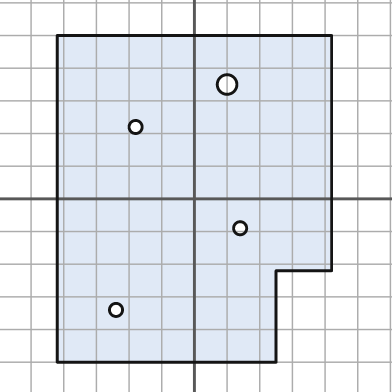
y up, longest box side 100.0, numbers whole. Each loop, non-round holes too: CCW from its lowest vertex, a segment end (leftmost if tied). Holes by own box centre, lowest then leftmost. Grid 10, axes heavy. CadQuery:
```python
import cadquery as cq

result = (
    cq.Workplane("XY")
    .moveTo(-42.0, -50.0)
    .lineTo(25.0, -50.0)
    .lineTo(25.0, -22.0)
    .lineTo(42.0, -22.0)
    .lineTo(42.0, 50.0)
    .lineTo(-42.0, 50.0)
    .close()
    .moveTo(-24.0, -34.0)
    .circle(2.0)
    .moveTo(14.0, -9.0)
    .circle(2.0)
    .moveTo(-18.0, 22.0)
    .circle(2.0)
    .moveTo(10.0, 35.0)
    .circle(3.0)
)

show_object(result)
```